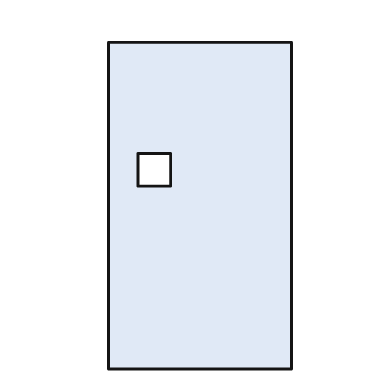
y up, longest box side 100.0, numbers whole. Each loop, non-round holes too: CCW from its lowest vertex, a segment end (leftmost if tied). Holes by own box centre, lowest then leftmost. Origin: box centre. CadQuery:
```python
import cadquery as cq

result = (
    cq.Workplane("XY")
    .moveTo(-28.0, -50.0)
    .lineTo(28.0, -50.0)
    .lineTo(28.0, 50.0)
    .lineTo(-28.0, 50.0)
    .close()
    .moveTo(-19.0, 6.0)
    .lineTo(-9.0, 6.0)
    .lineTo(-9.0, 16.0)
    .lineTo(-19.0, 16.0)
    .close()
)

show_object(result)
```